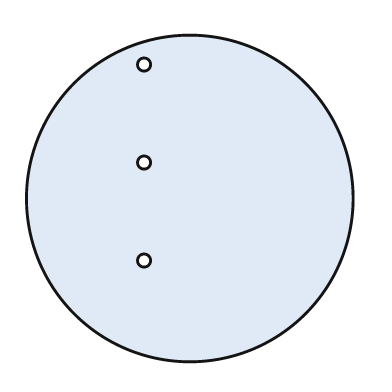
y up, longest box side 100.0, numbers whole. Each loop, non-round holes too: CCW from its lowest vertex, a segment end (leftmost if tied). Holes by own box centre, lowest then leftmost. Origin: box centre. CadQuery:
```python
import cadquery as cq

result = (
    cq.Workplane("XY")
    .moveTo(0.0, 0.0)
    .circle(50.0)
    .moveTo(-14.0, -19.0)
    .circle(2.0)
    .moveTo(-14.0, 11.0)
    .circle(2.0)
    .moveTo(-14.0, 41.0)
    .circle(2.0)
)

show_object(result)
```